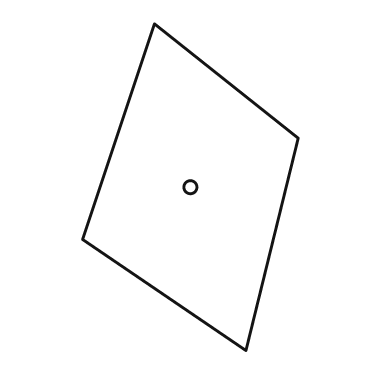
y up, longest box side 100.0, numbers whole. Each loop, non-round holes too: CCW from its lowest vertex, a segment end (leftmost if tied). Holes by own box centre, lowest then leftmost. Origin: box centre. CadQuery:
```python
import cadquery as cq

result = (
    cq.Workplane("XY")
    .moveTo(17.0, -50.0)
    .lineTo(33.0, 15.0)
    .lineTo(-11.0, 50.0)
    .lineTo(-33.0, -16.0)
    .close()
    .moveTo(0.0, 0.0)
    .circle(2.0)
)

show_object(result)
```